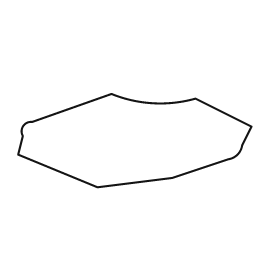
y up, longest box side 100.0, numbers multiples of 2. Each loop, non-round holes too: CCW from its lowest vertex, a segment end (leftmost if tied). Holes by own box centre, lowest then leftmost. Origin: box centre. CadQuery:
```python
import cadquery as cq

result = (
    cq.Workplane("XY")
    .moveTo(-16.0, -20.0)
    .lineTo(16.0, -16.0)
    .lineTo(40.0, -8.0)
    .threePointArc((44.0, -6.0), (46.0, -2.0))
    .lineTo(50.0, 6.0)
    .lineTo(26.0, 18.0)
    .threePointArc((8.0, 16.0), (-10.0, 20.0))
    .lineTo(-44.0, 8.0)
    .threePointArc((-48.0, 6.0), (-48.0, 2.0))
    .lineTo(-50.0, -6.0)
    .close()
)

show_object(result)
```